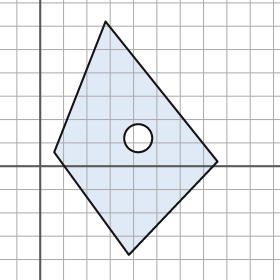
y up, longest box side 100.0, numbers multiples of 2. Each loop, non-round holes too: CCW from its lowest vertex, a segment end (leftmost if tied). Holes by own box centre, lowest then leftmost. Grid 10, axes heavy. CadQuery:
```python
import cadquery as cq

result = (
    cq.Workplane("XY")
    .moveTo(38.0, -38.0)
    .lineTo(76.0, 2.0)
    .lineTo(28.0, 62.0)
    .lineTo(6.0, 6.0)
    .close()
    .moveTo(42.0, 12.0)
    .circle(6.0)
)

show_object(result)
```